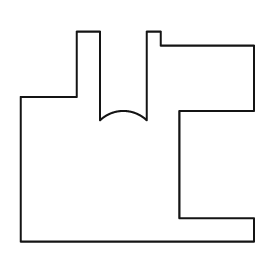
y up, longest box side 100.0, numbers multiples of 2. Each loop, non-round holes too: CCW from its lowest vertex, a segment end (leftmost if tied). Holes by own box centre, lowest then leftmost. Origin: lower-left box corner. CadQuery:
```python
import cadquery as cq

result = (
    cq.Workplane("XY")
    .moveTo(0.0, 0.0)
    .lineTo(100.0, 0.0)
    .lineTo(100.0, 10.0)
    .lineTo(68.0, 10.0)
    .lineTo(68.0, 56.0)
    .lineTo(100.0, 56.0)
    .lineTo(100.0, 84.0)
    .lineTo(60.0, 84.0)
    .lineTo(60.0, 90.0)
    .lineTo(54.0, 90.0)
    .lineTo(54.0, 52.0)
    .threePointArc((44.0, 56.0), (34.0, 52.0))
    .lineTo(34.0, 90.0)
    .lineTo(24.0, 90.0)
    .lineTo(24.0, 62.0)
    .lineTo(0.0, 62.0)
    .close()
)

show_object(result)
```